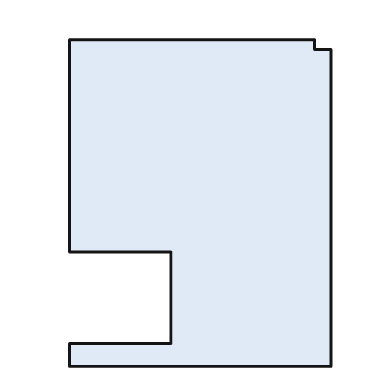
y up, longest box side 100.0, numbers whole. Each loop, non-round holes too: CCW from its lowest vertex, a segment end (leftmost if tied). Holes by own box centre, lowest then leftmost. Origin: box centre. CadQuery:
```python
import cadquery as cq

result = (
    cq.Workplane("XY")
    .moveTo(-40.0, -50.0)
    .lineTo(40.0, -50.0)
    .lineTo(40.0, 47.0)
    .lineTo(35.0, 47.0)
    .lineTo(35.0, 50.0)
    .lineTo(-40.0, 50.0)
    .lineTo(-40.0, -15.0)
    .lineTo(-9.0, -15.0)
    .lineTo(-9.0, -43.0)
    .lineTo(-40.0, -43.0)
    .close()
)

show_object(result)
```